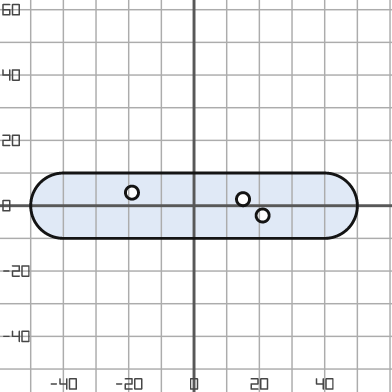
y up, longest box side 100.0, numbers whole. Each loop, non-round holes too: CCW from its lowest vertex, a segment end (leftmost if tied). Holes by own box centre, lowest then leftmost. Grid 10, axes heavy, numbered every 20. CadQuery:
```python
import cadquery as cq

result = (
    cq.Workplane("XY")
    .moveTo(-40.0, -10.0)
    .lineTo(40.0, -10.0)
    .threePointArc((50.0, 0.0), (40.0, 10.0))
    .lineTo(-40.0, 10.0)
    .threePointArc((-50.0, 0.0), (-40.0, -10.0))
    .close()
    .moveTo(21.0, -3.0)
    .circle(2.0)
    .moveTo(15.0, 2.0)
    .circle(2.0)
    .moveTo(-19.0, 4.0)
    .circle(2.0)
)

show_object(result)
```